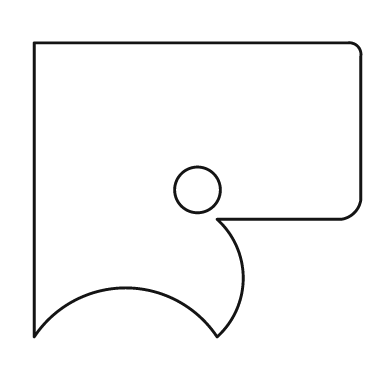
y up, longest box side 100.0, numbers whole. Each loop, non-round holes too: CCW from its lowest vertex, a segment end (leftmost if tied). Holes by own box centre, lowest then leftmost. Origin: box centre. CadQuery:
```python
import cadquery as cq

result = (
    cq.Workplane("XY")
    .moveTo(-50.0, -45.0)
    .threePointArc((-22.0, -30.0), (6.0, -45.0))
    .threePointArc((14.0, -27.0), (6.0, -9.0))
    .lineTo(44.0, -9.0)
    .threePointArc((48.0, -7.0), (50.0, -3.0))
    .lineTo(50.0, 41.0)
    .threePointArc((49.0, 44.0), (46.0, 45.0))
    .lineTo(-50.0, 45.0)
    .close()
    .moveTo(0.0, 0.0)
    .circle(7.0)
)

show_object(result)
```